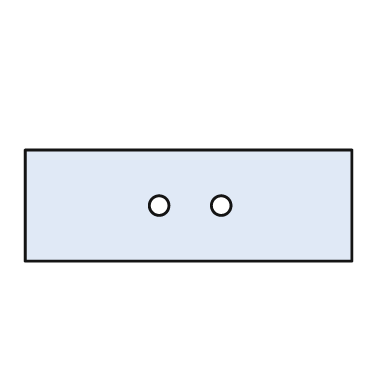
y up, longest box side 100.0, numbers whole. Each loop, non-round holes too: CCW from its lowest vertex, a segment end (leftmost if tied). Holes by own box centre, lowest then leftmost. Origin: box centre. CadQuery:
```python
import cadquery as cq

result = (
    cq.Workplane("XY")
    .moveTo(-50.0, -17.0)
    .lineTo(50.0, -17.0)
    .lineTo(50.0, 17.0)
    .lineTo(-50.0, 17.0)
    .close()
    .moveTo(-9.0, 0.0)
    .circle(3.0)
    .moveTo(10.0, 0.0)
    .circle(3.0)
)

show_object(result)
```